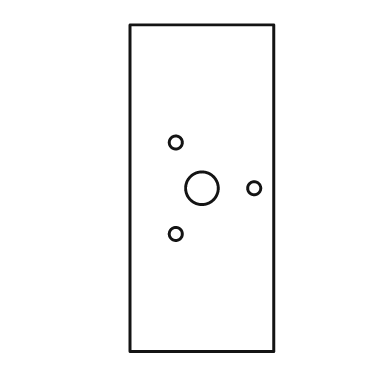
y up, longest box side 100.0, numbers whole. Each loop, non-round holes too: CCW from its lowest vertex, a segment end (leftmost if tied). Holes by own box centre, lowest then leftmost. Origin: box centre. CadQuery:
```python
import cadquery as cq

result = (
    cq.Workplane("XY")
    .moveTo(-22.0, -50.0)
    .lineTo(22.0, -50.0)
    .lineTo(22.0, 50.0)
    .lineTo(-22.0, 50.0)
    .close()
    .moveTo(-8.0, -14.0)
    .circle(2.0)
    .moveTo(0.0, 0.0)
    .circle(5.0)
    .moveTo(16.0, 0.0)
    .circle(2.0)
    .moveTo(-8.0, 14.0)
    .circle(2.0)
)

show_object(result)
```